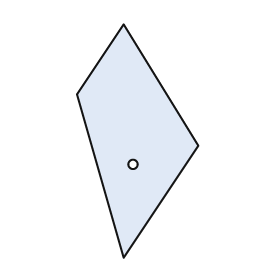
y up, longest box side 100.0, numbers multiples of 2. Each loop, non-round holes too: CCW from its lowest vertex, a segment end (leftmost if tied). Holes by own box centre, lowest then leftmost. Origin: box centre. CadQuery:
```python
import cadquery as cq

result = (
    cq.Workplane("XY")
    .moveTo(-6.0, -50.0)
    .lineTo(26.0, -2.0)
    .lineTo(-6.0, 50.0)
    .lineTo(-26.0, 20.0)
    .close()
    .moveTo(-2.0, -10.0)
    .circle(2.0)
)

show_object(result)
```